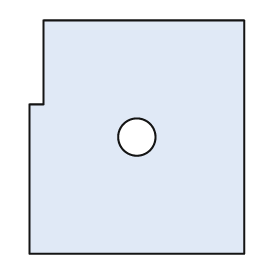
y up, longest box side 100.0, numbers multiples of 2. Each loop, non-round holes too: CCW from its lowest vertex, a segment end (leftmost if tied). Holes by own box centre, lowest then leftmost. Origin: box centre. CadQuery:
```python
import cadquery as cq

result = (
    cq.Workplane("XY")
    .moveTo(-46.0, -50.0)
    .lineTo(46.0, -50.0)
    .lineTo(46.0, 50.0)
    .lineTo(-40.0, 50.0)
    .lineTo(-40.0, 14.0)
    .lineTo(-46.0, 14.0)
    .close()
    .moveTo(0.0, 0.0)
    .circle(8.0)
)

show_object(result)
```